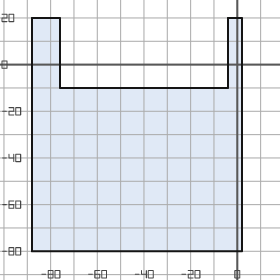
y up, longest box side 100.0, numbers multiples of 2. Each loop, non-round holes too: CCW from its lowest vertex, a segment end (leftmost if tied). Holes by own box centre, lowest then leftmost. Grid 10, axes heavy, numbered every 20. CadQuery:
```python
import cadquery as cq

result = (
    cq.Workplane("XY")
    .moveTo(-88.0, -80.0)
    .lineTo(2.0, -80.0)
    .lineTo(2.0, 20.0)
    .lineTo(-4.0, 20.0)
    .lineTo(-4.0, -10.0)
    .lineTo(-76.0, -10.0)
    .lineTo(-76.0, 20.0)
    .lineTo(-88.0, 20.0)
    .close()
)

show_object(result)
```